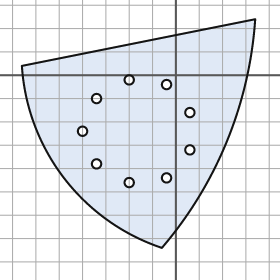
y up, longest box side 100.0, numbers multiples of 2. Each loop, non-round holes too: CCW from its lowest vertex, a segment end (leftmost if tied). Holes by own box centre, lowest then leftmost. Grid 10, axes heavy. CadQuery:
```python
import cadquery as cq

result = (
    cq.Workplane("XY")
    .moveTo(-6.0, -74.0)
    .threePointArc((22.0, -28.0), (34.0, 24.0))
    .lineTo(-66.0, 4.0)
    .threePointArc((-48.0, -44.0), (-6.0, -74.0))
    .close()
    .moveTo(-20.0, -46.0)
    .circle(2.0)
    .moveTo(-4.0, -44.0)
    .circle(2.0)
    .moveTo(-34.0, -38.0)
    .circle(2.0)
    .moveTo(6.0, -32.0)
    .circle(2.0)
    .moveTo(-40.0, -24.0)
    .circle(2.0)
    .moveTo(6.0, -16.0)
    .circle(2.0)
    .moveTo(-34.0, -10.0)
    .circle(2.0)
    .moveTo(-4.0, -4.0)
    .circle(2.0)
    .moveTo(-20.0, -2.0)
    .circle(2.0)
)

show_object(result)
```